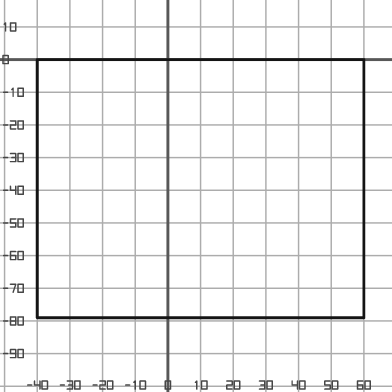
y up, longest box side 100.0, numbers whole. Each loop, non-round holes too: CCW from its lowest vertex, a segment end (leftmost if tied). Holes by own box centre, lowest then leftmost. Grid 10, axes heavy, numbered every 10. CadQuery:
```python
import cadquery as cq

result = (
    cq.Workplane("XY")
    .moveTo(-40.0, -79.0)
    .lineTo(60.0, -79.0)
    .lineTo(60.0, 0.0)
    .lineTo(-40.0, 0.0)
    .close()
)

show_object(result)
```